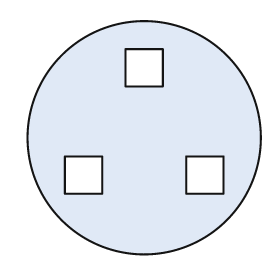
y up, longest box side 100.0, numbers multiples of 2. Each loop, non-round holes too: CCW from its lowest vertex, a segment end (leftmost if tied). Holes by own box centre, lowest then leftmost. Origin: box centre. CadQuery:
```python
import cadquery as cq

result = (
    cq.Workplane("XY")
    .moveTo(0.0, 0.0)
    .circle(50.0)
    .moveTo(-34.0, -24.0)
    .lineTo(-18.0, -24.0)
    .lineTo(-18.0, -8.0)
    .lineTo(-34.0, -8.0)
    .close()
    .moveTo(18.0, -24.0)
    .lineTo(34.0, -24.0)
    .lineTo(34.0, -8.0)
    .lineTo(18.0, -8.0)
    .close()
    .moveTo(-8.0, 22.0)
    .lineTo(8.0, 22.0)
    .lineTo(8.0, 38.0)
    .lineTo(-8.0, 38.0)
    .close()
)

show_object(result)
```